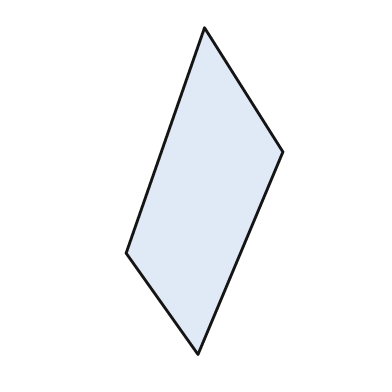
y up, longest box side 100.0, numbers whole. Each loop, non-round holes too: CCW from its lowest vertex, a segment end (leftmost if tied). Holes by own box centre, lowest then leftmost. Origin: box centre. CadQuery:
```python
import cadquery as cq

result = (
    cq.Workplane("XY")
    .moveTo(-2.0, -50.0)
    .lineTo(24.0, 12.0)
    .lineTo(0.0, 50.0)
    .lineTo(-24.0, -19.0)
    .close()
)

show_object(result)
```